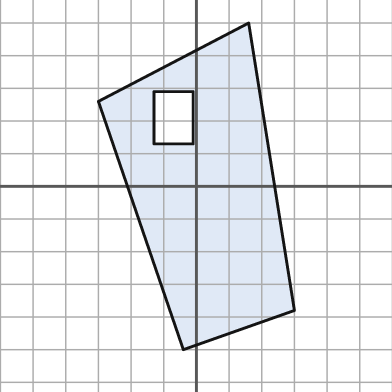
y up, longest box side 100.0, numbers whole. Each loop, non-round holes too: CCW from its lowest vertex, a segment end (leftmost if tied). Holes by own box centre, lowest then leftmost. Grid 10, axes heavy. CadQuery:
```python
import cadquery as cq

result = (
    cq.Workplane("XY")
    .moveTo(-4.0, -50.0)
    .lineTo(30.0, -38.0)
    .lineTo(16.0, 50.0)
    .lineTo(-30.0, 26.0)
    .close()
    .moveTo(-13.0, 13.0)
    .lineTo(-1.0, 13.0)
    .lineTo(-1.0, 29.0)
    .lineTo(-13.0, 29.0)
    .close()
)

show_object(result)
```